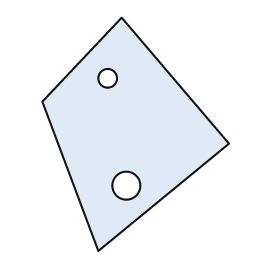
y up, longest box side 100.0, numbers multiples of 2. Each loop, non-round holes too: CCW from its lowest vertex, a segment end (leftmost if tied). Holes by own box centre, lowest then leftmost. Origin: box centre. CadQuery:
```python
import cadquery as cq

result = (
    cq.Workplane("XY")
    .moveTo(-16.0, -50.0)
    .lineTo(40.0, -4.0)
    .lineTo(-6.0, 50.0)
    .lineTo(-40.0, 14.0)
    .close()
    .moveTo(-4.0, -22.0)
    .circle(6.0)
    .moveTo(-12.0, 24.0)
    .circle(4.0)
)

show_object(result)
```